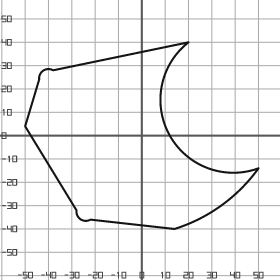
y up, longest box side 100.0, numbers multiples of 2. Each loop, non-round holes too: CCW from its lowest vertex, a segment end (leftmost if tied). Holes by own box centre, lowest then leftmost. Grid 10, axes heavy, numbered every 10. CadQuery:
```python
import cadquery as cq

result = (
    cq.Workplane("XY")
    .moveTo(14.0, -40.0)
    .threePointArc((34.0, -30.0), (50.0, -14.0))
    .threePointArc((12.0, 0.0), (20.0, 40.0))
    .lineTo(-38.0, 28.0)
    .threePointArc((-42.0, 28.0), (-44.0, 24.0))
    .lineTo(-50.0, 4.0)
    .lineTo(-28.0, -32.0)
    .threePointArc((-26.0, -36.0), (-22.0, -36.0))
    .close()
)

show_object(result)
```